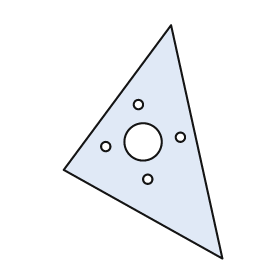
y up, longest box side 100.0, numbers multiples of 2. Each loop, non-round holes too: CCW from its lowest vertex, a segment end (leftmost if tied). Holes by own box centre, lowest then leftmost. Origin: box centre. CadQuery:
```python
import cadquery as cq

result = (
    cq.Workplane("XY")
    .moveTo(34.0, -50.0)
    .lineTo(12.0, 50.0)
    .lineTo(-34.0, -12.0)
    .close()
    .moveTo(2.0, -16.0)
    .circle(2.0)
    .moveTo(-16.0, -2.0)
    .circle(2.0)
    .moveTo(0.0, 0.0)
    .circle(8.0)
    .moveTo(16.0, 2.0)
    .circle(2.0)
    .moveTo(-2.0, 16.0)
    .circle(2.0)
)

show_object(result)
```